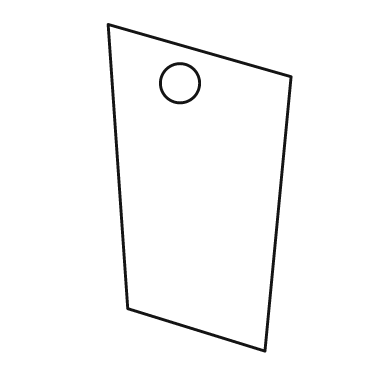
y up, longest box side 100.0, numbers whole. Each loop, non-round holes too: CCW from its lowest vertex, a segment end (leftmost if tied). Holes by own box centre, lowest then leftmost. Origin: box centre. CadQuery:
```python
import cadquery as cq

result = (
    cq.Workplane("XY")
    .moveTo(20.0, -50.0)
    .lineTo(28.0, 34.0)
    .lineTo(-28.0, 50.0)
    .lineTo(-22.0, -37.0)
    .close()
    .moveTo(-6.0, 32.0)
    .circle(6.0)
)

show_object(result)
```